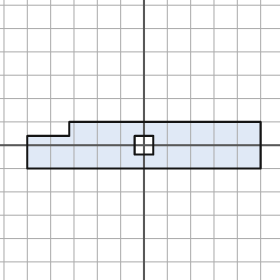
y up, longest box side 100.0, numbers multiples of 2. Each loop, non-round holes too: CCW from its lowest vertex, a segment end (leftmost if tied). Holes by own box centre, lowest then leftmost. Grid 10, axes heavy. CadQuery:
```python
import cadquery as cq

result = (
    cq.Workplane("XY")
    .moveTo(-50.0, -10.0)
    .lineTo(50.0, -10.0)
    .lineTo(50.0, 10.0)
    .lineTo(-32.0, 10.0)
    .lineTo(-32.0, 4.0)
    .lineTo(-50.0, 4.0)
    .close()
    .moveTo(-4.0, -4.0)
    .lineTo(4.0, -4.0)
    .lineTo(4.0, 4.0)
    .lineTo(-4.0, 4.0)
    .close()
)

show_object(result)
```